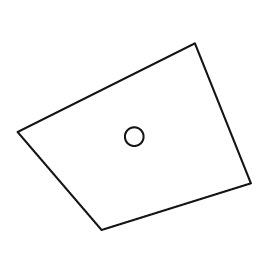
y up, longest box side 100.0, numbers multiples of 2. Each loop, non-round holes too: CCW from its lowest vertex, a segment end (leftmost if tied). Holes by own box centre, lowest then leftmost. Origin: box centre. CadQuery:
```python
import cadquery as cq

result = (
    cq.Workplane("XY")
    .moveTo(-14.0, -40.0)
    .lineTo(50.0, -20.0)
    .lineTo(26.0, 40.0)
    .lineTo(-50.0, 2.0)
    .close()
    .moveTo(0.0, 0.0)
    .circle(4.0)
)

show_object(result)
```